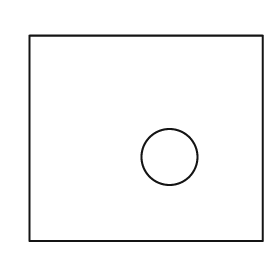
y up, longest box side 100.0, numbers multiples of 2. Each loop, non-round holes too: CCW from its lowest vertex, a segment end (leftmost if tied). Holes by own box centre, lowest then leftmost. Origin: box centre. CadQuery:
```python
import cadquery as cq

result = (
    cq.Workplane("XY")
    .moveTo(-50.0, -44.0)
    .lineTo(50.0, -44.0)
    .lineTo(50.0, 44.0)
    .lineTo(-50.0, 44.0)
    .close()
    .moveTo(10.0, -8.0)
    .circle(12.0)
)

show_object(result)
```